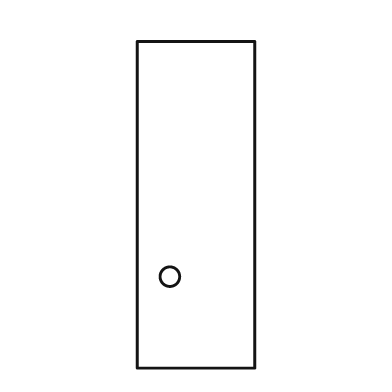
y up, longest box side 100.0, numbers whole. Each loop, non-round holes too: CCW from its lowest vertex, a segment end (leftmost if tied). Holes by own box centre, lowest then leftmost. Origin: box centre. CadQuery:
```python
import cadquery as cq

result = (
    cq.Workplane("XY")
    .moveTo(-18.0, -50.0)
    .lineTo(18.0, -50.0)
    .lineTo(18.0, 50.0)
    .lineTo(-18.0, 50.0)
    .close()
    .moveTo(-8.0, -22.0)
    .circle(3.0)
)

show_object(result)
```